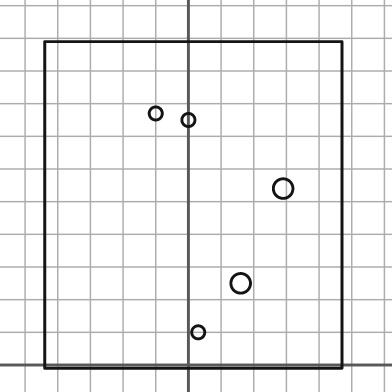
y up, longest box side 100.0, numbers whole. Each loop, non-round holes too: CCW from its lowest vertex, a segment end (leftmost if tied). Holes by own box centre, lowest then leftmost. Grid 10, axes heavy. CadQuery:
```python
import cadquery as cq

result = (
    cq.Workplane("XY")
    .moveTo(-44.0, -1.0)
    .lineTo(47.0, -1.0)
    .lineTo(47.0, 99.0)
    .lineTo(-44.0, 99.0)
    .close()
    .moveTo(3.0, 10.0)
    .circle(2.0)
    .moveTo(16.0, 25.0)
    .circle(3.0)
    .moveTo(29.0, 54.0)
    .circle(3.0)
    .moveTo(0.0, 75.0)
    .circle(2.0)
    .moveTo(-10.0, 77.0)
    .circle(2.0)
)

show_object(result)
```